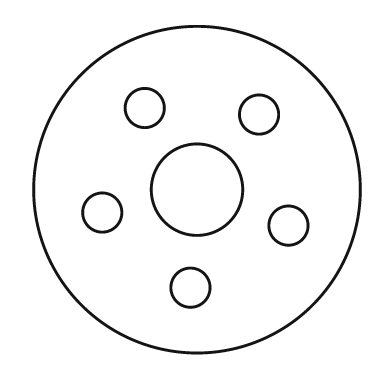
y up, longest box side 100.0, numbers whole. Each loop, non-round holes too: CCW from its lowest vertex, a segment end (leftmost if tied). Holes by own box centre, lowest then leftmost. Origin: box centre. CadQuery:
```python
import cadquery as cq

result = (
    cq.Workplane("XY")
    .moveTo(0.0, 0.0)
    .circle(50.0)
    .moveTo(-2.0, -30.0)
    .circle(6.0)
    .moveTo(28.0, -11.0)
    .circle(6.0)
    .moveTo(-29.0, -7.0)
    .circle(6.0)
    .moveTo(0.0, 0.0)
    .circle(14.0)
    .moveTo(19.0, 23.0)
    .circle(6.0)
    .moveTo(-16.0, 25.0)
    .circle(6.0)
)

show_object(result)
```